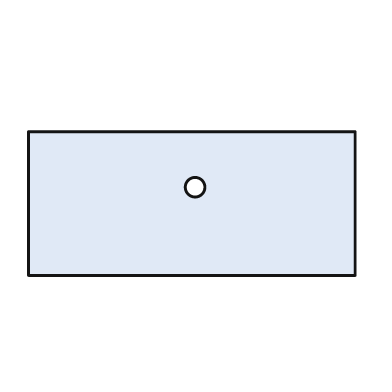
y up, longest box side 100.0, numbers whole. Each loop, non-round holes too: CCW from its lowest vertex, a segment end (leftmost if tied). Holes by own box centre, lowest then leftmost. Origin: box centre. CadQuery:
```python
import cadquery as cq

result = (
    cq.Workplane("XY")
    .moveTo(-50.0, -22.0)
    .lineTo(50.0, -22.0)
    .lineTo(50.0, 22.0)
    .lineTo(-50.0, 22.0)
    .close()
    .moveTo(1.0, 5.0)
    .circle(3.0)
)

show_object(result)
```